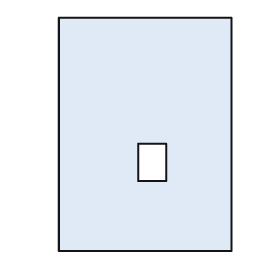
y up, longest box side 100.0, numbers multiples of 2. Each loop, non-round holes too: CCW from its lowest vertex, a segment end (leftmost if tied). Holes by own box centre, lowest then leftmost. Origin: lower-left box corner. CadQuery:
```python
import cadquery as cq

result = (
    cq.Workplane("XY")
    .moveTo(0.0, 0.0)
    .lineTo(74.0, 0.0)
    .lineTo(74.0, 100.0)
    .lineTo(0.0, 100.0)
    .close()
    .moveTo(34.0, 30.0)
    .lineTo(46.0, 30.0)
    .lineTo(46.0, 46.0)
    .lineTo(34.0, 46.0)
    .close()
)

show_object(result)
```